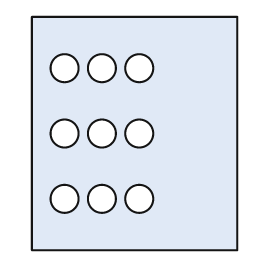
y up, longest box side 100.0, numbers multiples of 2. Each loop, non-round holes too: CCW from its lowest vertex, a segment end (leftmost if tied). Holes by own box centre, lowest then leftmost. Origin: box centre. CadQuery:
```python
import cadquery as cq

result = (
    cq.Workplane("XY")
    .moveTo(-44.0, -50.0)
    .lineTo(44.0, -50.0)
    .lineTo(44.0, 50.0)
    .lineTo(-44.0, 50.0)
    .close()
    .moveTo(-30.0, -28.0)
    .circle(6.0)
    .moveTo(-14.0, -28.0)
    .circle(6.0)
    .moveTo(2.0, -28.0)
    .circle(6.0)
    .moveTo(-30.0, 0.0)
    .circle(6.0)
    .moveTo(-14.0, 0.0)
    .circle(6.0)
    .moveTo(2.0, 0.0)
    .circle(6.0)
    .moveTo(-30.0, 28.0)
    .circle(6.0)
    .moveTo(-14.0, 28.0)
    .circle(6.0)
    .moveTo(2.0, 28.0)
    .circle(6.0)
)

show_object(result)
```